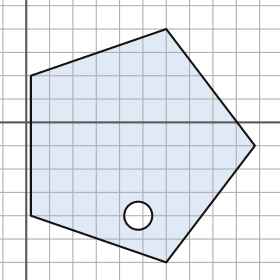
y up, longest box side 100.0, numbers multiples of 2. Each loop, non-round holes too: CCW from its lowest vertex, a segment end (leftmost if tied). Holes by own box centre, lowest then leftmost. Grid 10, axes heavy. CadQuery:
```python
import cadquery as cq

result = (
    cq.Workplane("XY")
    .moveTo(60.0, -60.0)
    .lineTo(98.0, -10.0)
    .lineTo(60.0, 40.0)
    .lineTo(2.0, 20.0)
    .lineTo(2.0, -40.0)
    .close()
    .moveTo(48.0, -40.0)
    .circle(6.0)
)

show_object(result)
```